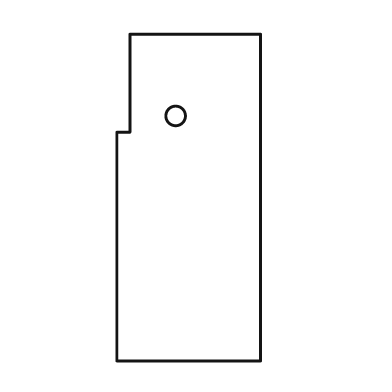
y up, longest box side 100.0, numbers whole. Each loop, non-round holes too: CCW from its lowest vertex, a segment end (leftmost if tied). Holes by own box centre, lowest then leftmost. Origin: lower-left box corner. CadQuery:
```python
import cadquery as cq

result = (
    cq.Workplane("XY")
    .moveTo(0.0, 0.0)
    .lineTo(44.0, 0.0)
    .lineTo(44.0, 100.0)
    .lineTo(4.0, 100.0)
    .lineTo(4.0, 70.0)
    .lineTo(0.0, 70.0)
    .close()
    .moveTo(18.0, 75.0)
    .circle(3.0)
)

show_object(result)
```